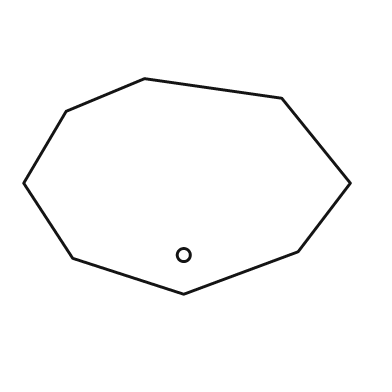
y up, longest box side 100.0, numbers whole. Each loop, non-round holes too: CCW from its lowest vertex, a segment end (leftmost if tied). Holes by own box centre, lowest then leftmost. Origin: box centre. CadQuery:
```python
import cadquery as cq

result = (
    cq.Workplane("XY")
    .moveTo(-1.0, -33.0)
    .lineTo(34.0, -20.0)
    .lineTo(50.0, 1.0)
    .lineTo(29.0, 27.0)
    .lineTo(-13.0, 33.0)
    .lineTo(-37.0, 23.0)
    .lineTo(-50.0, 1.0)
    .lineTo(-35.0, -22.0)
    .close()
    .moveTo(-1.0, -21.0)
    .circle(2.0)
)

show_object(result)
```